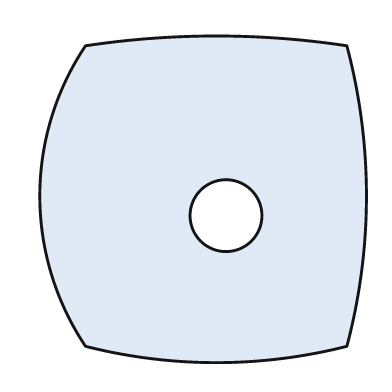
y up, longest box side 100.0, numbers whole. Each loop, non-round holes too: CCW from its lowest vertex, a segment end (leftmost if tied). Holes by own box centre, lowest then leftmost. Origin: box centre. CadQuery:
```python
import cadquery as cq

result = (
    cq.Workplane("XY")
    .moveTo(-36.0, -45.0)
    .threePointArc((4.0, -50.0), (44.0, -45.0))
    .threePointArc((50.0, 1.0), (44.0, 47.0))
    .threePointArc((4.0, 50.0), (-36.0, 47.0))
    .threePointArc((-50.0, 1.0), (-36.0, -45.0))
    .close()
    .moveTo(7.0, -5.0)
    .circle(11.0)
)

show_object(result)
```